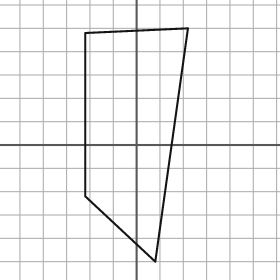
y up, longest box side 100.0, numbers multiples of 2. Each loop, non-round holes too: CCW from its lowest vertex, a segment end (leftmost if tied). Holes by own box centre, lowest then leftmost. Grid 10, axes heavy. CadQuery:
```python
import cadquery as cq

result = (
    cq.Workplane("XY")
    .moveTo(8.0, -50.0)
    .lineTo(22.0, 50.0)
    .lineTo(-22.0, 48.0)
    .lineTo(-22.0, -22.0)
    .close()
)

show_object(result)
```